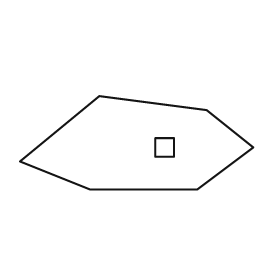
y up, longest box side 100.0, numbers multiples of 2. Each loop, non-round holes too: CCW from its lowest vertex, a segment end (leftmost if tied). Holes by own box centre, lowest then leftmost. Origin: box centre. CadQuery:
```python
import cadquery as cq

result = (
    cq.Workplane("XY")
    .moveTo(-20.0, -20.0)
    .lineTo(26.0, -20.0)
    .lineTo(50.0, -2.0)
    .lineTo(30.0, 14.0)
    .lineTo(-16.0, 20.0)
    .lineTo(-50.0, -8.0)
    .close()
    .moveTo(8.0, -6.0)
    .lineTo(16.0, -6.0)
    .lineTo(16.0, 2.0)
    .lineTo(8.0, 2.0)
    .close()
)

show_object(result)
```